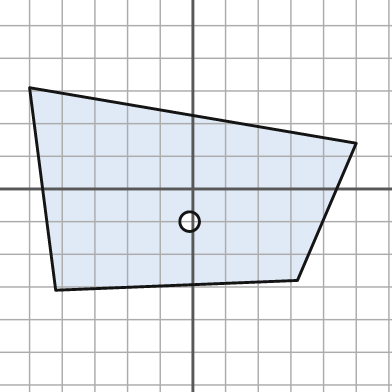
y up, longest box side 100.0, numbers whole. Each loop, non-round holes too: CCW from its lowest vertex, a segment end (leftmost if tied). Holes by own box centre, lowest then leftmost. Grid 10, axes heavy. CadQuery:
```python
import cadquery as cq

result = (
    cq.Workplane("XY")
    .moveTo(-42.0, -31.0)
    .lineTo(32.0, -28.0)
    .lineTo(50.0, 14.0)
    .lineTo(-50.0, 31.0)
    .close()
    .moveTo(-1.0, -10.0)
    .circle(3.0)
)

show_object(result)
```